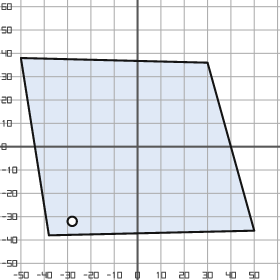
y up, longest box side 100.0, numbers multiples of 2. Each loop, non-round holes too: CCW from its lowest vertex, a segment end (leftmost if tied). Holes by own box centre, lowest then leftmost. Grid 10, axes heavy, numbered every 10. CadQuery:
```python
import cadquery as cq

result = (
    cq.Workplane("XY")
    .moveTo(-38.0, -38.0)
    .lineTo(50.0, -36.0)
    .lineTo(30.0, 36.0)
    .lineTo(-50.0, 38.0)
    .close()
    .moveTo(-28.0, -32.0)
    .circle(2.0)
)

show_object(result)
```